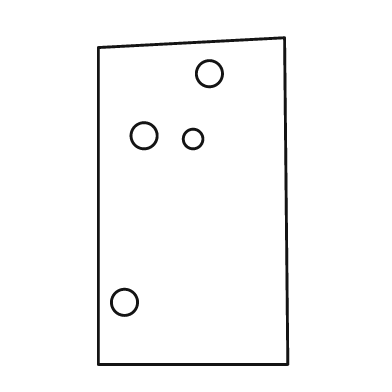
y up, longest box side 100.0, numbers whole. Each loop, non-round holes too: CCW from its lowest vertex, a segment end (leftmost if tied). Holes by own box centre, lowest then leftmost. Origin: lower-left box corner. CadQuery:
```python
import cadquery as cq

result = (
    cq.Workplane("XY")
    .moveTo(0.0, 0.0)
    .lineTo(58.0, 0.0)
    .lineTo(57.0, 100.0)
    .lineTo(0.0, 97.0)
    .close()
    .moveTo(8.0, 19.0)
    .circle(4.0)
    .moveTo(29.0, 69.0)
    .circle(3.0)
    .moveTo(14.0, 70.0)
    .circle(4.0)
    .moveTo(34.0, 89.0)
    .circle(4.0)
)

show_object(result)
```